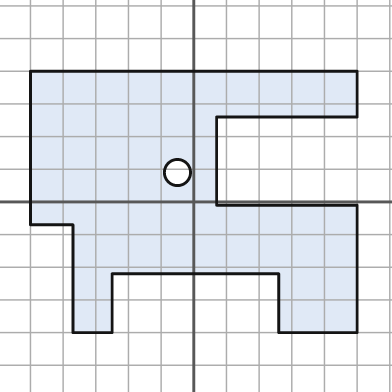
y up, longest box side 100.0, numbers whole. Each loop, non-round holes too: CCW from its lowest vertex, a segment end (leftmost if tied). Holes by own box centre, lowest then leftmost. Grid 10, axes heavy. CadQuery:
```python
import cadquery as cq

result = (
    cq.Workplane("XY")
    .moveTo(-37.0, -40.0)
    .lineTo(-25.0, -40.0)
    .lineTo(-25.0, -22.0)
    .lineTo(26.0, -22.0)
    .lineTo(26.0, -40.0)
    .lineTo(50.0, -40.0)
    .lineTo(50.0, -1.0)
    .lineTo(7.0, -1.0)
    .lineTo(7.0, 26.0)
    .lineTo(50.0, 26.0)
    .lineTo(50.0, 40.0)
    .lineTo(-50.0, 40.0)
    .lineTo(-50.0, -7.0)
    .lineTo(-37.0, -7.0)
    .close()
    .moveTo(-5.0, 9.0)
    .circle(4.0)
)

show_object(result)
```